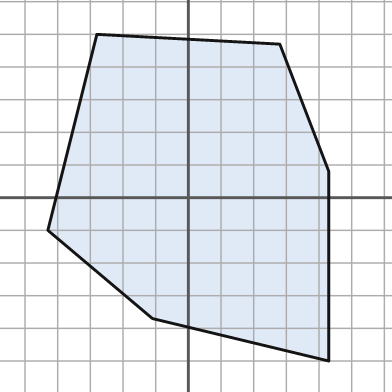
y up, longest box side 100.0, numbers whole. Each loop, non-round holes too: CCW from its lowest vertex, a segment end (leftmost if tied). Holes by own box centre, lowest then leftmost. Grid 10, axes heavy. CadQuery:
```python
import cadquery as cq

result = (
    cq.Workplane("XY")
    .moveTo(43.0, -50.0)
    .lineTo(43.0, 8.0)
    .lineTo(28.0, 47.0)
    .lineTo(-28.0, 50.0)
    .lineTo(-43.0, -10.0)
    .lineTo(-11.0, -37.0)
    .close()
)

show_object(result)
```